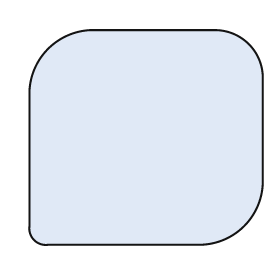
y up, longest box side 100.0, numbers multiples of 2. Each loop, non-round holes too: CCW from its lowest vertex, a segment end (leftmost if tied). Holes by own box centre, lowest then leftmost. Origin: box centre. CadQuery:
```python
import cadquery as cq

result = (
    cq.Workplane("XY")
    .moveTo(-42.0, -46.0)
    .lineTo(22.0, -46.0)
    .threePointArc((42.0, -38.0), (50.0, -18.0))
    .lineTo(50.0, 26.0)
    .threePointArc((44.0, 40.0), (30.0, 46.0))
    .lineTo(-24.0, 46.0)
    .threePointArc((-42.0, 38.0), (-50.0, 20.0))
    .lineTo(-50.0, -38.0)
    .threePointArc((-48.0, -44.0), (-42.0, -46.0))
    .close()
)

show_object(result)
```